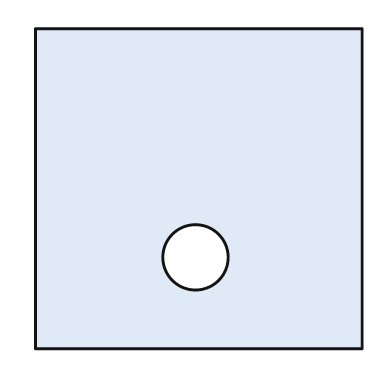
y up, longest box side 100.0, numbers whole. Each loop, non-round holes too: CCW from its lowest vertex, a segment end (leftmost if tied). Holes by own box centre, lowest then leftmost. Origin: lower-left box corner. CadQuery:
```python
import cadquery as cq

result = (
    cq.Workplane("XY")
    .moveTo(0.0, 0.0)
    .lineTo(100.0, 0.0)
    .lineTo(100.0, 98.0)
    .lineTo(0.0, 98.0)
    .close()
    .moveTo(49.0, 28.0)
    .circle(10.0)
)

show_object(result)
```